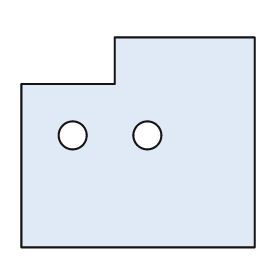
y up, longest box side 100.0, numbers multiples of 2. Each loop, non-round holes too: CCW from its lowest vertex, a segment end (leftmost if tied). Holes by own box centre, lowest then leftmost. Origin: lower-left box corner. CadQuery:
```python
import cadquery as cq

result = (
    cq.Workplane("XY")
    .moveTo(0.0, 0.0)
    .lineTo(100.0, 0.0)
    .lineTo(100.0, 90.0)
    .lineTo(40.0, 90.0)
    .lineTo(40.0, 70.0)
    .lineTo(0.0, 70.0)
    .close()
    .moveTo(22.0, 48.0)
    .circle(6.0)
    .moveTo(54.0, 48.0)
    .circle(6.0)
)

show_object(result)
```